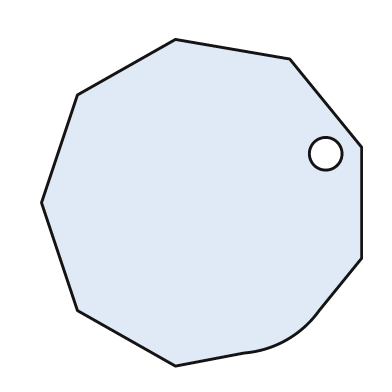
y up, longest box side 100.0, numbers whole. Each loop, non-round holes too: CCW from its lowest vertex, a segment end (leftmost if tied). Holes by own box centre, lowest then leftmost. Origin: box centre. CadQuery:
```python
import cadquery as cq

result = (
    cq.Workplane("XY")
    .moveTo(-8.0, -50.0)
    .lineTo(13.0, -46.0)
    .threePointArc((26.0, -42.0), (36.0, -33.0))
    .lineTo(49.0, -17.0)
    .lineTo(49.0, 17.0)
    .lineTo(27.0, 44.0)
    .lineTo(-8.0, 50.0)
    .lineTo(-38.0, 33.0)
    .lineTo(-49.0, 0.0)
    .lineTo(-38.0, -33.0)
    .close()
    .moveTo(38.0, 15.0)
    .circle(5.0)
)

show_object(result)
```